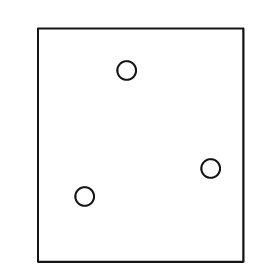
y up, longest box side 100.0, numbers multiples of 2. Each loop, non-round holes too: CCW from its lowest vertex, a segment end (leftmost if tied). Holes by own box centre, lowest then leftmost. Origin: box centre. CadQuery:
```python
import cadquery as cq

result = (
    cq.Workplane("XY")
    .moveTo(-44.0, -50.0)
    .lineTo(44.0, -50.0)
    .lineTo(44.0, 50.0)
    .lineTo(-44.0, 50.0)
    .close()
    .moveTo(-24.0, -22.0)
    .circle(4.0)
    .moveTo(30.0, -10.0)
    .circle(4.0)
    .moveTo(-6.0, 32.0)
    .circle(4.0)
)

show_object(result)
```